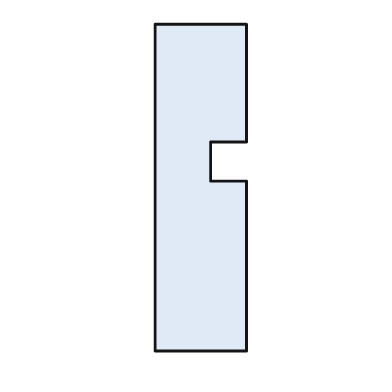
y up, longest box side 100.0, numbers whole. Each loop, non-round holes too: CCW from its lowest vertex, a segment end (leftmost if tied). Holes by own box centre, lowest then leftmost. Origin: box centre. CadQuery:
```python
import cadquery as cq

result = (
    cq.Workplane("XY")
    .moveTo(-14.0, -50.0)
    .lineTo(14.0, -50.0)
    .lineTo(14.0, 2.0)
    .lineTo(3.0, 2.0)
    .lineTo(3.0, 14.0)
    .lineTo(14.0, 14.0)
    .lineTo(14.0, 50.0)
    .lineTo(-14.0, 50.0)
    .close()
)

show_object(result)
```